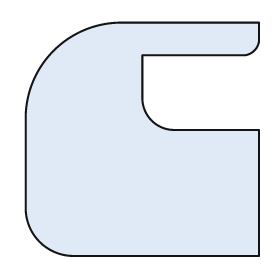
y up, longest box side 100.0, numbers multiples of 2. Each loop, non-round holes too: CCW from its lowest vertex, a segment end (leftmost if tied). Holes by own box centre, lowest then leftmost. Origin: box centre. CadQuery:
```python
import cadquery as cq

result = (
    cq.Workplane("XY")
    .moveTo(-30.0, -50.0)
    .lineTo(50.0, -50.0)
    .lineTo(50.0, 4.0)
    .lineTo(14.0, 4.0)
    .threePointArc((4.0, 8.0), (0.0, 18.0))
    .lineTo(0.0, 36.0)
    .lineTo(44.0, 36.0)
    .threePointArc((48.0, 38.0), (50.0, 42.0))
    .lineTo(50.0, 50.0)
    .lineTo(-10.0, 50.0)
    .threePointArc((-38.0, 38.0), (-50.0, 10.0))
    .lineTo(-50.0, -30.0)
    .threePointArc((-44.0, -44.0), (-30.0, -50.0))
    .close()
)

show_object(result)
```